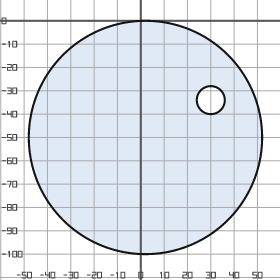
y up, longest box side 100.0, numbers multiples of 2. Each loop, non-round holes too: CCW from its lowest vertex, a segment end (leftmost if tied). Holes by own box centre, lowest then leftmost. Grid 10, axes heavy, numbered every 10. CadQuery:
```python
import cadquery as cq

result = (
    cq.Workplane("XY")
    .moveTo(2.0, -50.0)
    .circle(50.0)
    .moveTo(30.0, -34.0)
    .circle(6.0)
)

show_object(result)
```